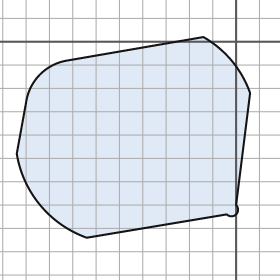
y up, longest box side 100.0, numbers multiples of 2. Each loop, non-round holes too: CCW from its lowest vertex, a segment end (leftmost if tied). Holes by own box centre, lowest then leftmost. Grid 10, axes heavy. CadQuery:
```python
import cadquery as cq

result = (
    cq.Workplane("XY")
    .moveTo(-64.0, -84.0)
    .lineTo(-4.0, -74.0)
    .threePointArc((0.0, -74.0), (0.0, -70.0))
    .lineTo(6.0, -22.0)
    .threePointArc((-2.0, -8.0), (-14.0, 2.0))
    .lineTo(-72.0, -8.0)
    .threePointArc((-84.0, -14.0), (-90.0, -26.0))
    .lineTo(-94.0, -48.0)
    .threePointArc((-84.0, -70.0), (-64.0, -84.0))
    .close()
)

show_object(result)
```